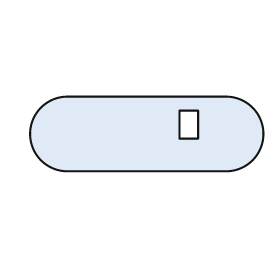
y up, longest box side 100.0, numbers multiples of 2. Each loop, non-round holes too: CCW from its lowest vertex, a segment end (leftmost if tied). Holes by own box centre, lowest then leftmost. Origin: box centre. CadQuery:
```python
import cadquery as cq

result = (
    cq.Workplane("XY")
    .moveTo(-34.0, -16.0)
    .lineTo(34.0, -16.0)
    .threePointArc((50.0, 0.0), (34.0, 16.0))
    .lineTo(-34.0, 16.0)
    .threePointArc((-50.0, 0.0), (-34.0, -16.0))
    .close()
    .moveTo(14.0, -2.0)
    .lineTo(22.0, -2.0)
    .lineTo(22.0, 10.0)
    .lineTo(14.0, 10.0)
    .close()
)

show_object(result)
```